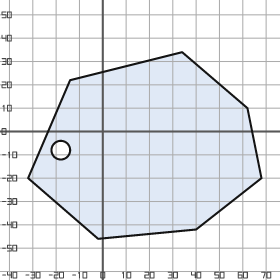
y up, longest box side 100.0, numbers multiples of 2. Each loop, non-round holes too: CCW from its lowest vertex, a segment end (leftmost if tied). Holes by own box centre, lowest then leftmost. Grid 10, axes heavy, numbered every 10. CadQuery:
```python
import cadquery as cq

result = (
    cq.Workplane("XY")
    .moveTo(-2.0, -46.0)
    .lineTo(40.0, -42.0)
    .lineTo(68.0, -20.0)
    .lineTo(62.0, 10.0)
    .lineTo(34.0, 34.0)
    .lineTo(-14.0, 22.0)
    .lineTo(-32.0, -20.0)
    .close()
    .moveTo(-18.0, -8.0)
    .circle(4.0)
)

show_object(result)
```